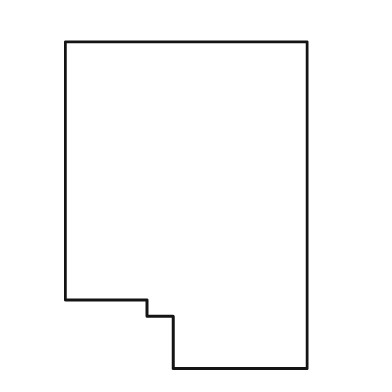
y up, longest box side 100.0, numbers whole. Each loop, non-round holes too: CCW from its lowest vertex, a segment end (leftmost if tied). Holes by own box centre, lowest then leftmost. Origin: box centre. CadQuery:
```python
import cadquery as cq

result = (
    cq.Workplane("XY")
    .moveTo(-4.0, -50.0)
    .lineTo(37.0, -50.0)
    .lineTo(37.0, 50.0)
    .lineTo(-37.0, 50.0)
    .lineTo(-37.0, -29.0)
    .lineTo(-12.0, -29.0)
    .lineTo(-12.0, -34.0)
    .lineTo(-4.0, -34.0)
    .close()
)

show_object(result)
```